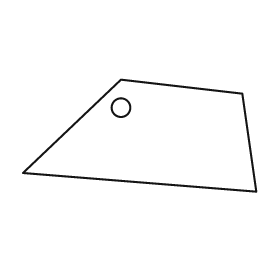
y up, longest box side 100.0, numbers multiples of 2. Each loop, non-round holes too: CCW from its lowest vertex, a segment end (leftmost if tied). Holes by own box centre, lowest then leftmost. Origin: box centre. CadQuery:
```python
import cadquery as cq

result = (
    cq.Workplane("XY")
    .moveTo(50.0, -24.0)
    .lineTo(44.0, 18.0)
    .lineTo(-8.0, 24.0)
    .lineTo(-50.0, -16.0)
    .close()
    .moveTo(-8.0, 12.0)
    .circle(4.0)
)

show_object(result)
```